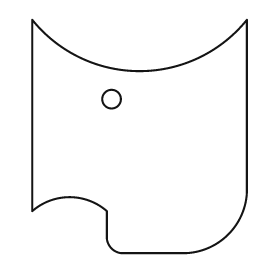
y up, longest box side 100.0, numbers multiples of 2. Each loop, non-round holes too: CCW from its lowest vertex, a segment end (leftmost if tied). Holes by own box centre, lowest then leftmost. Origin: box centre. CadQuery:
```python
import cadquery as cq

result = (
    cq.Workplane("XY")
    .moveTo(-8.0, -50.0)
    .lineTo(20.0, -50.0)
    .threePointArc((38.0, -42.0), (46.0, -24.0))
    .lineTo(46.0, 50.0)
    .threePointArc((0.0, 28.0), (-46.0, 50.0))
    .lineTo(-46.0, -32.0)
    .threePointArc((-30.0, -26.0), (-14.0, -32.0))
    .lineTo(-14.0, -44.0)
    .threePointArc((-12.0, -48.0), (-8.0, -50.0))
    .close()
    .moveTo(-12.0, 16.0)
    .circle(4.0)
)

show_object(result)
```